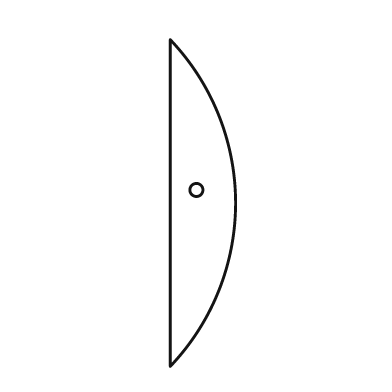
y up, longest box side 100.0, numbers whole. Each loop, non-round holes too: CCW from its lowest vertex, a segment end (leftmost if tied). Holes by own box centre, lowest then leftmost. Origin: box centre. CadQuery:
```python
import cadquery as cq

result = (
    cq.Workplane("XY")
    .moveTo(-10.0, -50.0)
    .threePointArc((10.0, 0.0), (-10.0, 50.0))
    .close()
    .moveTo(-2.0, 4.0)
    .circle(2.0)
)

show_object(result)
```